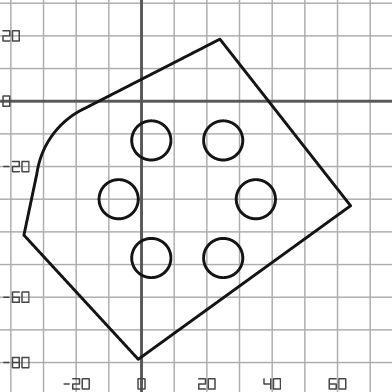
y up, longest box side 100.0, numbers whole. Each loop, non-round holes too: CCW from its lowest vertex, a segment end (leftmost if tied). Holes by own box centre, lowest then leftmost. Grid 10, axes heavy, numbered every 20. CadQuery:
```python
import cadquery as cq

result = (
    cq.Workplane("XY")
    .moveTo(-1.0, -79.0)
    .lineTo(64.0, -32.0)
    .lineTo(24.0, 19.0)
    .lineTo(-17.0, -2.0)
    .threePointArc((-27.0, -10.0), (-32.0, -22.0))
    .lineTo(-36.0, -41.0)
    .close()
    .moveTo(3.0, -48.0)
    .circle(6.0)
    .moveTo(25.0, -48.0)
    .circle(6.0)
    .moveTo(-7.0, -30.0)
    .circle(6.0)
    .moveTo(35.0, -30.0)
    .circle(6.0)
    .moveTo(3.0, -12.0)
    .circle(6.0)
    .moveTo(25.0, -12.0)
    .circle(6.0)
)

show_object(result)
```